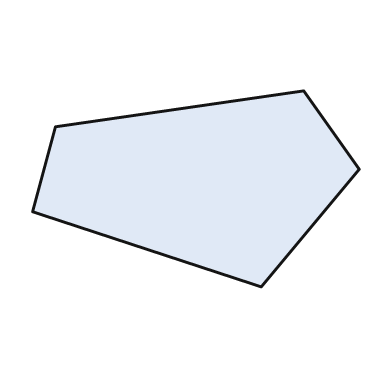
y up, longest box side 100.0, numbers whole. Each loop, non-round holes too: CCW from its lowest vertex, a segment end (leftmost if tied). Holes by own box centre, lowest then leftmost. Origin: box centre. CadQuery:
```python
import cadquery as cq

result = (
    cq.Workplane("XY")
    .moveTo(20.0, -30.0)
    .lineTo(50.0, 6.0)
    .lineTo(33.0, 30.0)
    .lineTo(-43.0, 19.0)
    .lineTo(-50.0, -7.0)
    .close()
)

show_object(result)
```